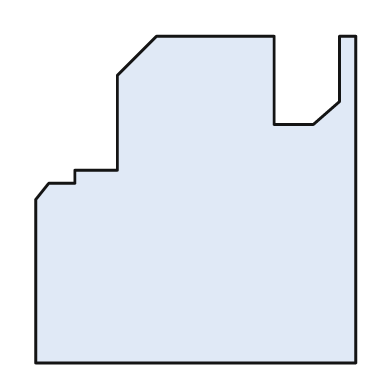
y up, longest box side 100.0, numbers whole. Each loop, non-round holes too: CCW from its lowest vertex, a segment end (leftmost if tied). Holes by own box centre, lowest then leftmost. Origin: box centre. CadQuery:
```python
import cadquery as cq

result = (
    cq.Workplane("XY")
    .moveTo(-49.0, -50.0)
    .lineTo(49.0, -50.0)
    .lineTo(49.0, 50.0)
    .lineTo(44.0, 50.0)
    .lineTo(44.0, 30.0)
    .lineTo(36.0, 23.0)
    .lineTo(24.0, 23.0)
    .lineTo(24.0, 50.0)
    .lineTo(-12.0, 50.0)
    .lineTo(-24.0, 38.0)
    .lineTo(-24.0, 9.0)
    .lineTo(-37.0, 9.0)
    .lineTo(-37.0, 5.0)
    .lineTo(-45.0, 5.0)
    .lineTo(-49.0, 0.0)
    .close()
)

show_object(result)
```